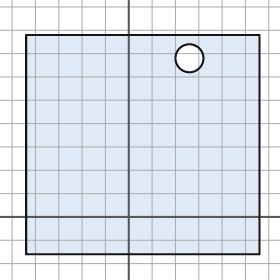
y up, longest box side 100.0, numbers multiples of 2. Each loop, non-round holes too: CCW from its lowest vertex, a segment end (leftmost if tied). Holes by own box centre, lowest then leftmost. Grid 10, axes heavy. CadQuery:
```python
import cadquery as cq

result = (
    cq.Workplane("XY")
    .moveTo(-44.0, -16.0)
    .lineTo(56.0, -16.0)
    .lineTo(56.0, 78.0)
    .lineTo(-44.0, 78.0)
    .close()
    .moveTo(26.0, 68.0)
    .circle(6.0)
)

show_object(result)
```